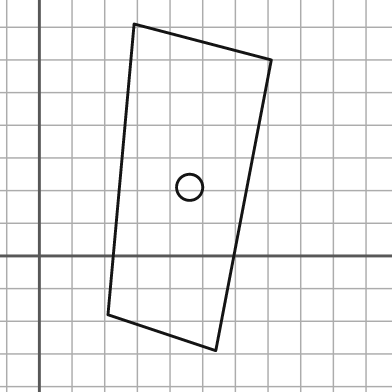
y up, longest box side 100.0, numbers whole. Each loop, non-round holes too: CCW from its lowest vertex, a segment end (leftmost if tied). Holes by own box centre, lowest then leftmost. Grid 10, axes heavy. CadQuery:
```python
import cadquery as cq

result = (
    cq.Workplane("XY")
    .moveTo(54.0, -29.0)
    .lineTo(71.0, 60.0)
    .lineTo(29.0, 71.0)
    .lineTo(21.0, -18.0)
    .close()
    .moveTo(46.0, 21.0)
    .circle(4.0)
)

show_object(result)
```